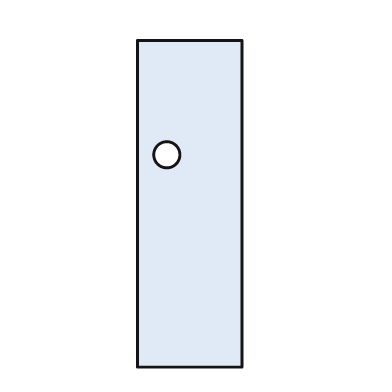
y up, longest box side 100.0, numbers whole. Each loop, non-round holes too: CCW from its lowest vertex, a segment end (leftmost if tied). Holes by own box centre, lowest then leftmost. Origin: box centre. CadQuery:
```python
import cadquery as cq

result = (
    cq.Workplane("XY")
    .moveTo(-16.0, -50.0)
    .lineTo(16.0, -50.0)
    .lineTo(16.0, 50.0)
    .lineTo(-16.0, 50.0)
    .close()
    .moveTo(-7.0, 15.0)
    .circle(4.0)
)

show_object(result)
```